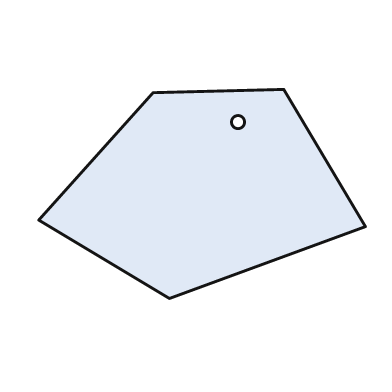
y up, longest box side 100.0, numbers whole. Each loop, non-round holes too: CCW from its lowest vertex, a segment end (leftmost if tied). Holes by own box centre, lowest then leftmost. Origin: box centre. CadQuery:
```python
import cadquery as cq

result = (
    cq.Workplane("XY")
    .moveTo(-10.0, -32.0)
    .lineTo(50.0, -10.0)
    .lineTo(25.0, 32.0)
    .lineTo(-15.0, 31.0)
    .lineTo(-50.0, -8.0)
    .close()
    .moveTo(11.0, 22.0)
    .circle(2.0)
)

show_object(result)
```